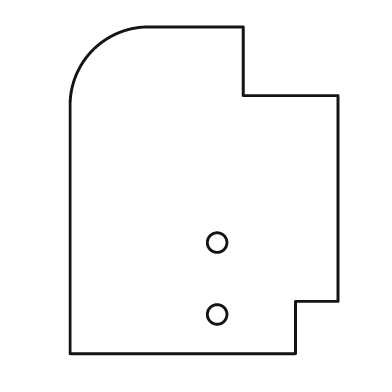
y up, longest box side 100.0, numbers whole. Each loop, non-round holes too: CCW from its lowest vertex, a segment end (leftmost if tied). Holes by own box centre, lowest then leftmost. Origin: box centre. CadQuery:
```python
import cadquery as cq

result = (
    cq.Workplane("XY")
    .moveTo(-41.0, -50.0)
    .lineTo(28.0, -50.0)
    .lineTo(28.0, -34.0)
    .lineTo(41.0, -34.0)
    .lineTo(41.0, 29.0)
    .lineTo(12.0, 29.0)
    .lineTo(12.0, 50.0)
    .lineTo(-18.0, 50.0)
    .threePointArc((-34.0, 43.0), (-41.0, 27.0))
    .close()
    .moveTo(4.0, -38.0)
    .circle(3.0)
    .moveTo(4.0, -16.0)
    .circle(3.0)
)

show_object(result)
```